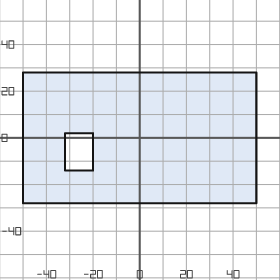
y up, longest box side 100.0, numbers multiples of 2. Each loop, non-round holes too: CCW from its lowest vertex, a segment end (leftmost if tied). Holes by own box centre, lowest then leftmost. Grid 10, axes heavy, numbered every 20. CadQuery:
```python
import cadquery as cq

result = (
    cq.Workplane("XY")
    .moveTo(-50.0, -28.0)
    .lineTo(50.0, -28.0)
    .lineTo(50.0, 28.0)
    .lineTo(-50.0, 28.0)
    .close()
    .moveTo(-32.0, -14.0)
    .lineTo(-20.0, -14.0)
    .lineTo(-20.0, 2.0)
    .lineTo(-32.0, 2.0)
    .close()
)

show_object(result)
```